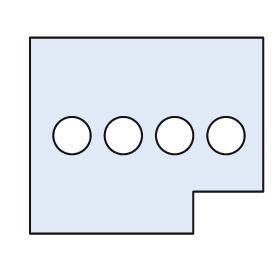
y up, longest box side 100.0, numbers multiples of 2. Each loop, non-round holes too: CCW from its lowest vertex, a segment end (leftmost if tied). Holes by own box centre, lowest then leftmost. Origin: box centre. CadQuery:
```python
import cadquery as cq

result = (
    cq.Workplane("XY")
    .moveTo(-50.0, -42.0)
    .lineTo(20.0, -42.0)
    .lineTo(20.0, -24.0)
    .lineTo(50.0, -24.0)
    .lineTo(50.0, 42.0)
    .lineTo(-50.0, 42.0)
    .close()
    .moveTo(-32.0, 0.0)
    .circle(8.0)
    .moveTo(-10.0, 0.0)
    .circle(8.0)
    .moveTo(12.0, 0.0)
    .circle(8.0)
    .moveTo(34.0, 0.0)
    .circle(8.0)
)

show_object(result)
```